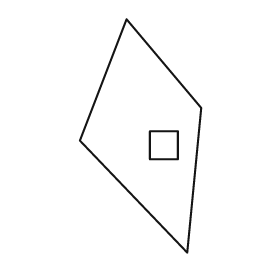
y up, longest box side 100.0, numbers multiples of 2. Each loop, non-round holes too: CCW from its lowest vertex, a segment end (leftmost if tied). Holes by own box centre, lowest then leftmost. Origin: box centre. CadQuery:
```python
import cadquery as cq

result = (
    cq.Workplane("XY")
    .moveTo(20.0, -50.0)
    .lineTo(26.0, 12.0)
    .lineTo(-6.0, 50.0)
    .lineTo(-26.0, -2.0)
    .close()
    .moveTo(4.0, -10.0)
    .lineTo(16.0, -10.0)
    .lineTo(16.0, 2.0)
    .lineTo(4.0, 2.0)
    .close()
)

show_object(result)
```